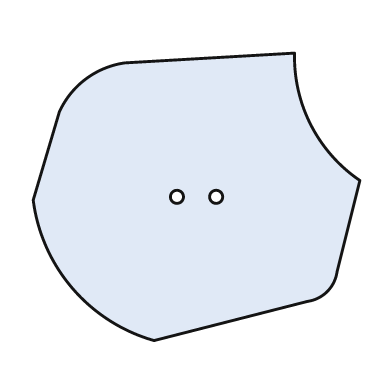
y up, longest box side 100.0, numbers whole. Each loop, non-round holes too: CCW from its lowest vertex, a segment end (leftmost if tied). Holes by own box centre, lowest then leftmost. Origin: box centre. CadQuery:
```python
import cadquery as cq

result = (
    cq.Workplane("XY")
    .moveTo(-13.0, -44.0)
    .lineTo(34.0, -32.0)
    .threePointArc((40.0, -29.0), (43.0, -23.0))
    .lineTo(50.0, 5.0)
    .threePointArc((35.0, 22.0), (30.0, 44.0))
    .lineTo(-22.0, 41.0)
    .threePointArc((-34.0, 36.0), (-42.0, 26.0))
    .lineTo(-50.0, -1.0)
    .threePointArc((-38.0, -28.0), (-13.0, -44.0))
    .close()
    .moveTo(-6.0, 0.0)
    .circle(2.0)
    .moveTo(6.0, 0.0)
    .circle(2.0)
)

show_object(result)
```